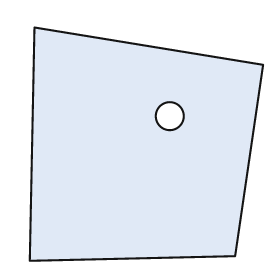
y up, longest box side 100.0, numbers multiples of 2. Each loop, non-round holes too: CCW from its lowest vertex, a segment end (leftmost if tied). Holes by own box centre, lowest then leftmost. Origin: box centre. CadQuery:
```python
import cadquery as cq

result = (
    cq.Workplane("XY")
    .moveTo(-50.0, -50.0)
    .lineTo(38.0, -48.0)
    .lineTo(50.0, 34.0)
    .lineTo(-48.0, 50.0)
    .close()
    .moveTo(10.0, 12.0)
    .circle(6.0)
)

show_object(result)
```